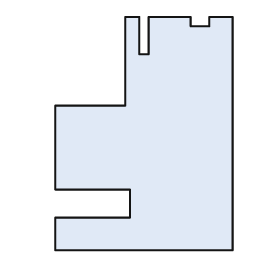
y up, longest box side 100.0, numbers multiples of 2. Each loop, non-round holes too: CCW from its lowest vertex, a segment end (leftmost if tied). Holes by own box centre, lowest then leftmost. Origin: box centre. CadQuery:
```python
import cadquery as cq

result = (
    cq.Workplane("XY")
    .moveTo(-38.0, -50.0)
    .lineTo(38.0, -50.0)
    .lineTo(38.0, 50.0)
    .lineTo(28.0, 50.0)
    .lineTo(28.0, 46.0)
    .lineTo(20.0, 46.0)
    .lineTo(20.0, 50.0)
    .lineTo(2.0, 50.0)
    .lineTo(2.0, 34.0)
    .lineTo(-2.0, 34.0)
    .lineTo(-2.0, 50.0)
    .lineTo(-8.0, 50.0)
    .lineTo(-8.0, 12.0)
    .lineTo(-38.0, 12.0)
    .lineTo(-38.0, -24.0)
    .lineTo(-6.0, -24.0)
    .lineTo(-6.0, -36.0)
    .lineTo(-38.0, -36.0)
    .close()
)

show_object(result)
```